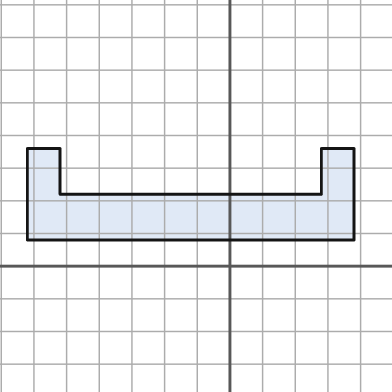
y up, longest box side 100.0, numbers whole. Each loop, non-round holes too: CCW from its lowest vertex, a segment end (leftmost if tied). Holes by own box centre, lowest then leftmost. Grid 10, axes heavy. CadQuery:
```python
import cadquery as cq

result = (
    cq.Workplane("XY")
    .moveTo(-62.0, 8.0)
    .lineTo(38.0, 8.0)
    .lineTo(38.0, 36.0)
    .lineTo(28.0, 36.0)
    .lineTo(28.0, 22.0)
    .lineTo(-52.0, 22.0)
    .lineTo(-52.0, 36.0)
    .lineTo(-62.0, 36.0)
    .close()
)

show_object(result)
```